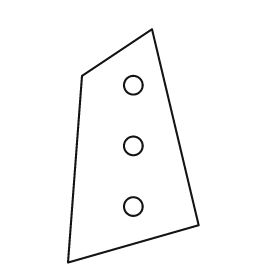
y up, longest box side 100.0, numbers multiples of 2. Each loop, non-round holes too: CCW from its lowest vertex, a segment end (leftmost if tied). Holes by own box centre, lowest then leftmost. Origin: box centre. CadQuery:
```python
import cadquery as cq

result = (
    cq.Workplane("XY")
    .moveTo(-28.0, -50.0)
    .lineTo(28.0, -34.0)
    .lineTo(8.0, 50.0)
    .lineTo(-22.0, 30.0)
    .close()
    .moveTo(0.0, -26.0)
    .circle(4.0)
    .moveTo(0.0, 0.0)
    .circle(4.0)
    .moveTo(0.0, 26.0)
    .circle(4.0)
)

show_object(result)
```